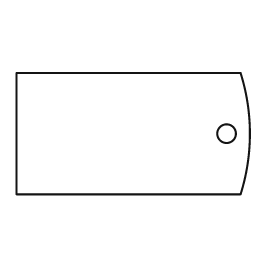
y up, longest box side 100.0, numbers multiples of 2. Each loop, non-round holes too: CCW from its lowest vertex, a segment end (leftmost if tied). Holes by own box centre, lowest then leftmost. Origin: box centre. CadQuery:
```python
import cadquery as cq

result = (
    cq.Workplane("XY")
    .moveTo(-50.0, -26.0)
    .lineTo(46.0, -26.0)
    .threePointArc((50.0, 0.0), (46.0, 26.0))
    .lineTo(-50.0, 26.0)
    .close()
    .moveTo(40.0, 0.0)
    .circle(4.0)
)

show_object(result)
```